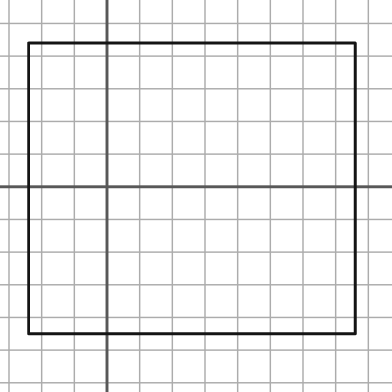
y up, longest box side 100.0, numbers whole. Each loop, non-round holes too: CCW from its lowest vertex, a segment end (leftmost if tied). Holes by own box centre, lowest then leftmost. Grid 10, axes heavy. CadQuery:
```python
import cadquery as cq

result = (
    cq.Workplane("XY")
    .moveTo(-24.0, -45.0)
    .lineTo(76.0, -45.0)
    .lineTo(76.0, 44.0)
    .lineTo(-24.0, 44.0)
    .close()
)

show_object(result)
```